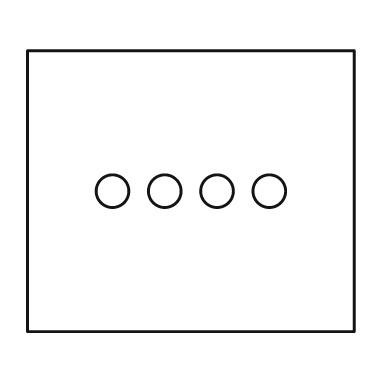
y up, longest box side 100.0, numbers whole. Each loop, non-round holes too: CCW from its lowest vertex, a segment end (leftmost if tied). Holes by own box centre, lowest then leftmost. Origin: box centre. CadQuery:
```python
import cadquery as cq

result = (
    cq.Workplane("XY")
    .moveTo(-50.0, -43.0)
    .lineTo(50.0, -43.0)
    .lineTo(50.0, 43.0)
    .lineTo(-50.0, 43.0)
    .close()
    .moveTo(-24.0, 0.0)
    .circle(5.0)
    .moveTo(-8.0, 0.0)
    .circle(5.0)
    .moveTo(8.0, 0.0)
    .circle(5.0)
    .moveTo(24.0, 0.0)
    .circle(5.0)
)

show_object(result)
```